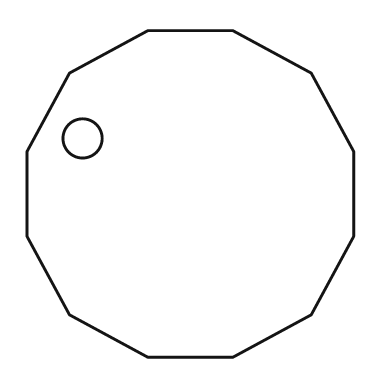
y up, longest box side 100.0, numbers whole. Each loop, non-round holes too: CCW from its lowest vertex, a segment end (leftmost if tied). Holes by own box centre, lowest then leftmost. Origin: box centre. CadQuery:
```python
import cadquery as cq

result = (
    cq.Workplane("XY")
    .moveTo(-13.0, -50.0)
    .lineTo(13.0, -50.0)
    .lineTo(37.0, -37.0)
    .lineTo(50.0, -13.0)
    .lineTo(50.0, 13.0)
    .lineTo(37.0, 37.0)
    .lineTo(13.0, 50.0)
    .lineTo(-13.0, 50.0)
    .lineTo(-37.0, 37.0)
    .lineTo(-50.0, 13.0)
    .lineTo(-50.0, -13.0)
    .lineTo(-37.0, -37.0)
    .close()
    .moveTo(-33.0, 17.0)
    .circle(6.0)
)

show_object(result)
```